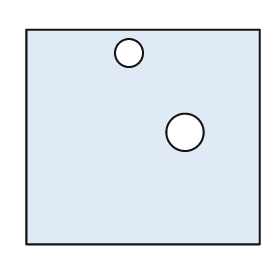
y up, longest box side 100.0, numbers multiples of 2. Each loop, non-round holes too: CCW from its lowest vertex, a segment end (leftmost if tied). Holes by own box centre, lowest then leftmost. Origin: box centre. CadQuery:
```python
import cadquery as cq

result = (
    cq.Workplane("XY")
    .moveTo(-50.0, -46.0)
    .lineTo(50.0, -46.0)
    .lineTo(50.0, 46.0)
    .lineTo(-50.0, 46.0)
    .close()
    .moveTo(18.0, 2.0)
    .circle(8.0)
    .moveTo(-6.0, 36.0)
    .circle(6.0)
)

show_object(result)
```